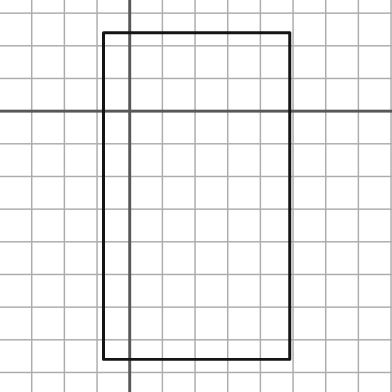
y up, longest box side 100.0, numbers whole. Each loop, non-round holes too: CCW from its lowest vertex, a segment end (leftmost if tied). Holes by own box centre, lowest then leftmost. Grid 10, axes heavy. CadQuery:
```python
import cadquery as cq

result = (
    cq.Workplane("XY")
    .moveTo(-8.0, -76.0)
    .lineTo(49.0, -76.0)
    .lineTo(49.0, 24.0)
    .lineTo(-8.0, 24.0)
    .close()
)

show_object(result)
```